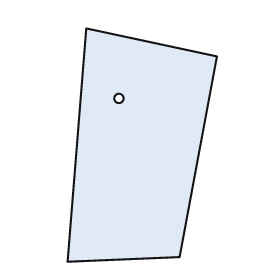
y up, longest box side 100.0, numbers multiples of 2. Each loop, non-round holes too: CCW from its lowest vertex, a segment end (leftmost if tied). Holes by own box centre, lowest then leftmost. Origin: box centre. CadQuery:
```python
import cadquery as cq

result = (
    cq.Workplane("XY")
    .moveTo(-32.0, -50.0)
    .lineTo(16.0, -48.0)
    .lineTo(32.0, 38.0)
    .lineTo(-24.0, 50.0)
    .close()
    .moveTo(-10.0, 20.0)
    .circle(2.0)
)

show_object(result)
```